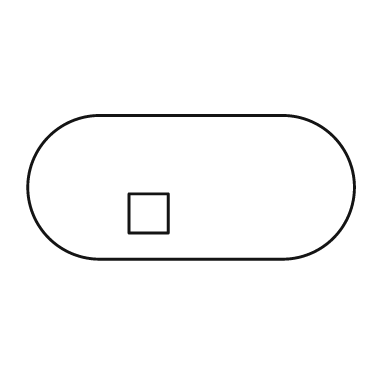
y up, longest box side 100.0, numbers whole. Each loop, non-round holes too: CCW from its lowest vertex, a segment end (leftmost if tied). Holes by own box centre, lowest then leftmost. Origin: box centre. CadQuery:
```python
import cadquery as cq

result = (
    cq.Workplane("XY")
    .moveTo(-28.0, -22.0)
    .lineTo(28.0, -22.0)
    .threePointArc((50.0, 0.0), (28.0, 22.0))
    .lineTo(-28.0, 22.0)
    .threePointArc((-50.0, 0.0), (-28.0, -22.0))
    .close()
    .moveTo(-19.0, -14.0)
    .lineTo(-7.0, -14.0)
    .lineTo(-7.0, -2.0)
    .lineTo(-19.0, -2.0)
    .close()
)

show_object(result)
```